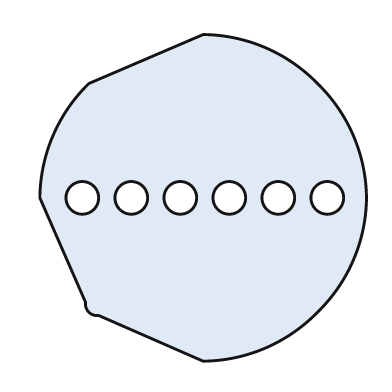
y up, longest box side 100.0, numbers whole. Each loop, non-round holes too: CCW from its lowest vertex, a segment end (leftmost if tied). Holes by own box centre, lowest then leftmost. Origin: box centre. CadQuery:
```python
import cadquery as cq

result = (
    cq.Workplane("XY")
    .moveTo(0.0, -50.0)
    .threePointArc((19.0, -46.0), (35.0, -35.0))
    .threePointArc((46.0, -19.0), (50.0, 0.0))
    .threePointArc((46.0, 19.0), (35.0, 35.0))
    .threePointArc((19.0, 46.0), (0.0, 50.0))
    .lineTo(-35.0, 35.0)
    .threePointArc((-46.0, 19.0), (-50.0, 0.0))
    .lineTo(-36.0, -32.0)
    .threePointArc((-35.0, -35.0), (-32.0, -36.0))
    .close()
    .moveTo(-37.0, 0.0)
    .circle(5.0)
    .moveTo(-22.0, 0.0)
    .circle(5.0)
    .moveTo(-7.0, 0.0)
    .circle(5.0)
    .moveTo(8.0, 0.0)
    .circle(5.0)
    .moveTo(23.0, 0.0)
    .circle(5.0)
    .moveTo(38.0, 0.0)
    .circle(5.0)
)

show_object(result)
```